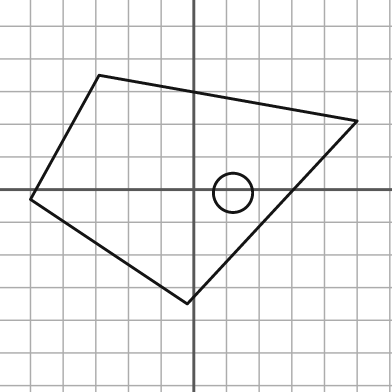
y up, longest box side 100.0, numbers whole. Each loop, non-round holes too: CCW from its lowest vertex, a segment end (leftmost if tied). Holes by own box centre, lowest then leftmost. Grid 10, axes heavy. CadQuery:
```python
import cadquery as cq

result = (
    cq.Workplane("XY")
    .moveTo(-2.0, -35.0)
    .lineTo(50.0, 21.0)
    .lineTo(-29.0, 35.0)
    .lineTo(-50.0, -3.0)
    .close()
    .moveTo(12.0, -1.0)
    .circle(6.0)
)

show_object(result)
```